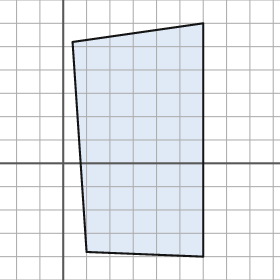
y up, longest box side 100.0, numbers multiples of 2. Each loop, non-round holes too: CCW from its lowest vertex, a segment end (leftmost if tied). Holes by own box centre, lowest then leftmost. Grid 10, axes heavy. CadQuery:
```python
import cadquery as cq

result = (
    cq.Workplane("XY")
    .moveTo(60.0, -40.0)
    .lineTo(60.0, 60.0)
    .lineTo(4.0, 52.0)
    .lineTo(10.0, -38.0)
    .close()
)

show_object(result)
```